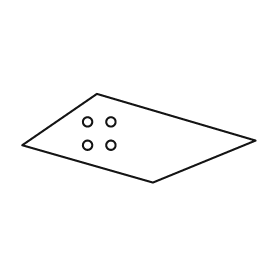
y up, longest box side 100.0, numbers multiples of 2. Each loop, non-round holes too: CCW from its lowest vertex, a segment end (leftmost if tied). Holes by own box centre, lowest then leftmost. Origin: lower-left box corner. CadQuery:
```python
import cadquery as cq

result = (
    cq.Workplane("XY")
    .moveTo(56.0, 0.0)
    .lineTo(100.0, 18.0)
    .lineTo(32.0, 38.0)
    .lineTo(0.0, 16.0)
    .close()
    .moveTo(28.0, 16.0)
    .circle(2.0)
    .moveTo(38.0, 16.0)
    .circle(2.0)
    .moveTo(28.0, 26.0)
    .circle(2.0)
    .moveTo(38.0, 26.0)
    .circle(2.0)
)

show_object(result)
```